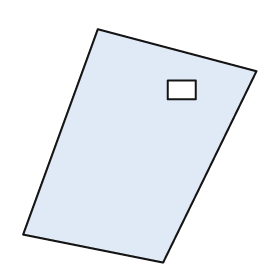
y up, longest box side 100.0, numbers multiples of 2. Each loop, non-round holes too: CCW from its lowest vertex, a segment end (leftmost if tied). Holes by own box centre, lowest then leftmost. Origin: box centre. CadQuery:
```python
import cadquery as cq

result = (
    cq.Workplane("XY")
    .moveTo(10.0, -50.0)
    .lineTo(50.0, 32.0)
    .lineTo(-18.0, 50.0)
    .lineTo(-50.0, -38.0)
    .close()
    .moveTo(12.0, 20.0)
    .lineTo(24.0, 20.0)
    .lineTo(24.0, 28.0)
    .lineTo(12.0, 28.0)
    .close()
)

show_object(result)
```